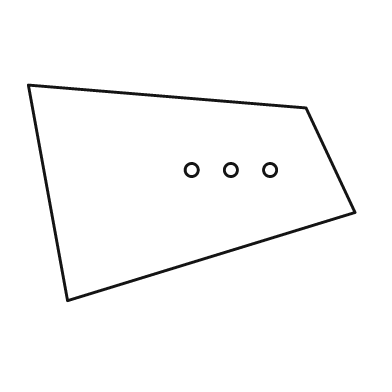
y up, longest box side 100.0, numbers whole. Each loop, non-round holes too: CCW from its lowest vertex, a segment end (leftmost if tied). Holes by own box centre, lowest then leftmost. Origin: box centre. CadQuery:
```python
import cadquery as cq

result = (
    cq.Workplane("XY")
    .moveTo(-38.0, -33.0)
    .lineTo(50.0, -6.0)
    .lineTo(35.0, 26.0)
    .lineTo(-50.0, 33.0)
    .close()
    .moveTo(0.0, 7.0)
    .circle(2.0)
    .moveTo(12.0, 7.0)
    .circle(2.0)
    .moveTo(24.0, 7.0)
    .circle(2.0)
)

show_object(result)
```